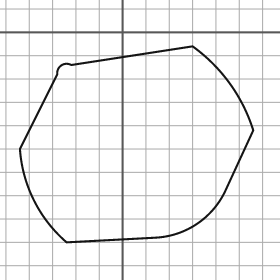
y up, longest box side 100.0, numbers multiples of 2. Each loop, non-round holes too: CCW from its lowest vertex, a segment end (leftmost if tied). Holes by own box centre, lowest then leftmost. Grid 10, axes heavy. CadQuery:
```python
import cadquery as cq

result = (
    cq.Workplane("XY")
    .moveTo(-24.0, -90.0)
    .lineTo(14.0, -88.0)
    .threePointArc((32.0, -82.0), (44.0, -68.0))
    .lineTo(56.0, -42.0)
    .threePointArc((46.0, -22.0), (30.0, -6.0))
    .lineTo(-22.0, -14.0)
    .threePointArc((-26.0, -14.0), (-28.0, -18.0))
    .lineTo(-44.0, -50.0)
    .threePointArc((-38.0, -72.0), (-24.0, -90.0))
    .close()
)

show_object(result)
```